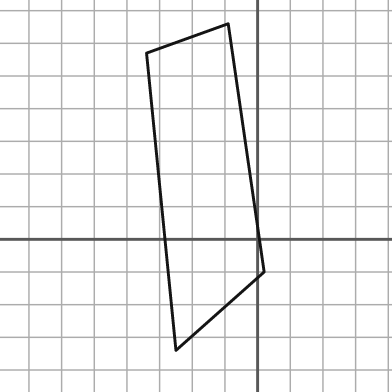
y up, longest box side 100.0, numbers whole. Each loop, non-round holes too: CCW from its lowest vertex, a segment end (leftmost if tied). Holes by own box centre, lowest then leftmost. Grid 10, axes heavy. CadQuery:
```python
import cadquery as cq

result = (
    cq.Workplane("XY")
    .moveTo(-25.0, -34.0)
    .lineTo(2.0, -10.0)
    .lineTo(-9.0, 66.0)
    .lineTo(-34.0, 57.0)
    .close()
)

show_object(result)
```